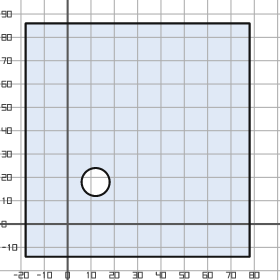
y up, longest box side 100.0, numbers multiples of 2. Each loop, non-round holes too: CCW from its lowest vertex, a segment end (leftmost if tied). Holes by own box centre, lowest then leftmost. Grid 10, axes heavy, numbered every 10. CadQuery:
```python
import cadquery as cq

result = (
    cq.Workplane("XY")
    .moveTo(-18.0, -14.0)
    .lineTo(78.0, -14.0)
    .lineTo(78.0, 86.0)
    .lineTo(-18.0, 86.0)
    .close()
    .moveTo(12.0, 18.0)
    .circle(6.0)
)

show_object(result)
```